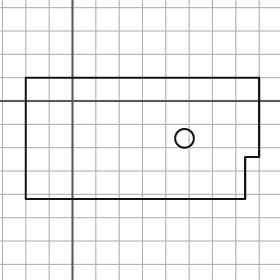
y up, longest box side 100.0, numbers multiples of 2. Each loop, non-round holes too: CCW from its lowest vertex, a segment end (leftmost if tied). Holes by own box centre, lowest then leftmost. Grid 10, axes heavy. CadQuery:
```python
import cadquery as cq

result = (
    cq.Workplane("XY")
    .moveTo(-20.0, -42.0)
    .lineTo(74.0, -42.0)
    .lineTo(74.0, -24.0)
    .lineTo(80.0, -24.0)
    .lineTo(80.0, 10.0)
    .lineTo(-20.0, 10.0)
    .close()
    .moveTo(48.0, -16.0)
    .circle(4.0)
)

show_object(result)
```